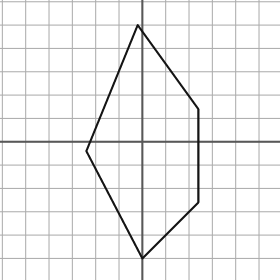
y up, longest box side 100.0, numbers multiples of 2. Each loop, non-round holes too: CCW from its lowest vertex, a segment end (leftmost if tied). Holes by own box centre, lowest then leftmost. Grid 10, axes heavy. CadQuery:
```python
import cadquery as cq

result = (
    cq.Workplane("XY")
    .moveTo(0.0, -50.0)
    .lineTo(24.0, -26.0)
    .lineTo(24.0, 14.0)
    .lineTo(-2.0, 50.0)
    .lineTo(-24.0, -4.0)
    .close()
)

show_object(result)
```